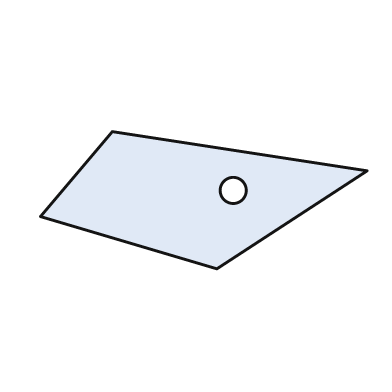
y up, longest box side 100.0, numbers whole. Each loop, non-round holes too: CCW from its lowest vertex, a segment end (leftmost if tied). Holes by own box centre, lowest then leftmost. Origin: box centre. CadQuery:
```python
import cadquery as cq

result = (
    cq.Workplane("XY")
    .moveTo(4.0, -21.0)
    .lineTo(50.0, 9.0)
    .lineTo(-28.0, 21.0)
    .lineTo(-50.0, -5.0)
    .close()
    .moveTo(9.0, 3.0)
    .circle(4.0)
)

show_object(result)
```